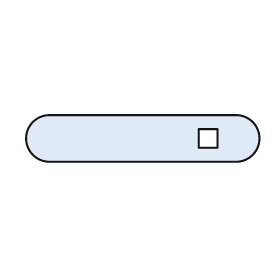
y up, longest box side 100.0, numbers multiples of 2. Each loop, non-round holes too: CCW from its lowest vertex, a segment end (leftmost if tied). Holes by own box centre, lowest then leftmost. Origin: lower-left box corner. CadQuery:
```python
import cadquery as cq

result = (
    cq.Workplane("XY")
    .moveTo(10.0, 0.0)
    .lineTo(90.0, 0.0)
    .threePointArc((100.0, 10.0), (90.0, 20.0))
    .lineTo(10.0, 20.0)
    .threePointArc((0.0, 10.0), (10.0, 0.0))
    .close()
    .moveTo(74.0, 6.0)
    .lineTo(82.0, 6.0)
    .lineTo(82.0, 14.0)
    .lineTo(74.0, 14.0)
    .close()
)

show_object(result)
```